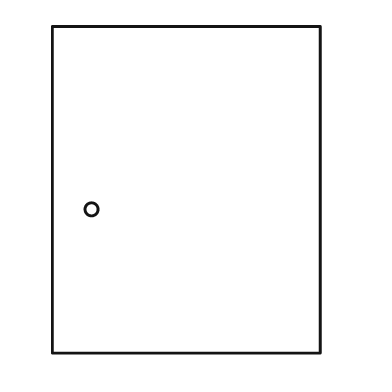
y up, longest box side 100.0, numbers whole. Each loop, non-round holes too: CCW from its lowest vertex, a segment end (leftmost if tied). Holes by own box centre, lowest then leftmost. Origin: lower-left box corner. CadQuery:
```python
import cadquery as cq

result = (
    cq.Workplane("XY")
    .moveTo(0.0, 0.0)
    .lineTo(82.0, 0.0)
    .lineTo(82.0, 100.0)
    .lineTo(0.0, 100.0)
    .close()
    .moveTo(12.0, 44.0)
    .circle(2.0)
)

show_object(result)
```